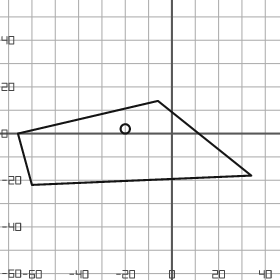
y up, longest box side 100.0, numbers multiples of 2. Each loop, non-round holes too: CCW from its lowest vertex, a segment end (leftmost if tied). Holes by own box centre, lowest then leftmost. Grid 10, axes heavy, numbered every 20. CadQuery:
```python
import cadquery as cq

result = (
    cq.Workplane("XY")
    .moveTo(-60.0, -22.0)
    .lineTo(34.0, -18.0)
    .lineTo(-6.0, 14.0)
    .lineTo(-66.0, 0.0)
    .close()
    .moveTo(-20.0, 2.0)
    .circle(2.0)
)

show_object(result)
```